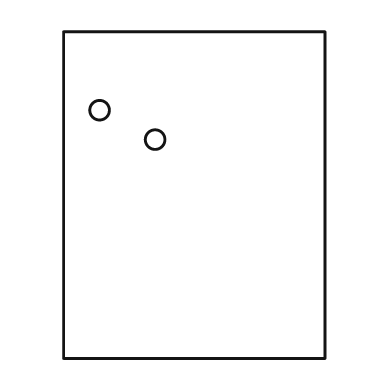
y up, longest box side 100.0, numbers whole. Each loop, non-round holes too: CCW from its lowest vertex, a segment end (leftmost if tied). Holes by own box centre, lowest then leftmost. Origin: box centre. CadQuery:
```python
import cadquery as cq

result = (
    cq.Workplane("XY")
    .moveTo(-40.0, -50.0)
    .lineTo(40.0, -50.0)
    .lineTo(40.0, 50.0)
    .lineTo(-40.0, 50.0)
    .close()
    .moveTo(-12.0, 17.0)
    .circle(3.0)
    .moveTo(-29.0, 26.0)
    .circle(3.0)
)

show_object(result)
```